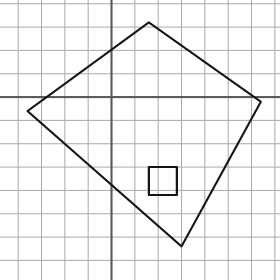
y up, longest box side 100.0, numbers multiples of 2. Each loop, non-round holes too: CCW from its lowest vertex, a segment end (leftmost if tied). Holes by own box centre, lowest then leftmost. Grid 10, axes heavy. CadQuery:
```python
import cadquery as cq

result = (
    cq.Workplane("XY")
    .moveTo(30.0, -64.0)
    .lineTo(64.0, -2.0)
    .lineTo(16.0, 32.0)
    .lineTo(-36.0, -6.0)
    .close()
    .moveTo(16.0, -42.0)
    .lineTo(28.0, -42.0)
    .lineTo(28.0, -30.0)
    .lineTo(16.0, -30.0)
    .close()
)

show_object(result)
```